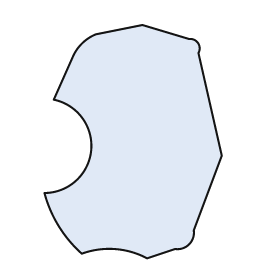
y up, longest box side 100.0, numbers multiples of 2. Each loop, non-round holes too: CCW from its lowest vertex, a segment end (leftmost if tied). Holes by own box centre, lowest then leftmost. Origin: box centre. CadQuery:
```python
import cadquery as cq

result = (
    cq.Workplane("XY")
    .moveTo(6.0, -50.0)
    .lineTo(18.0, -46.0)
    .threePointArc((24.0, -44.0), (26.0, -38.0))
    .lineTo(38.0, -6.0)
    .lineTo(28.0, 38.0)
    .threePointArc((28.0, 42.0), (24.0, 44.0))
    .lineTo(4.0, 50.0)
    .lineTo(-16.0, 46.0)
    .threePointArc((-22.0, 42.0), (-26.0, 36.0))
    .lineTo(-34.0, 18.0)
    .threePointArc((-18.0, -4.0), (-38.0, -22.0))
    .threePointArc((-32.0, -36.0), (-22.0, -48.0))
    .threePointArc((-8.0, -46.0), (6.0, -50.0))
    .close()
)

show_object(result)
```